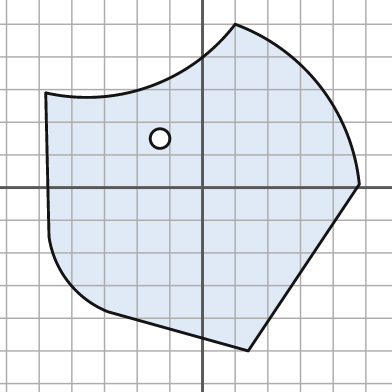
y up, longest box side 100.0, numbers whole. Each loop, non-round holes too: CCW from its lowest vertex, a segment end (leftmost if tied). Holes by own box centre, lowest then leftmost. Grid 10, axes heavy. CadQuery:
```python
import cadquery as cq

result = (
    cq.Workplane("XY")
    .moveTo(14.0, -50.0)
    .lineTo(48.0, 1.0)
    .threePointArc((36.0, 31.0), (10.0, 50.0))
    .threePointArc((-16.0, 31.0), (-48.0, 29.0))
    .lineTo(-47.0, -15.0)
    .threePointArc((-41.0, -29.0), (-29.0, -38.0))
    .close()
    .moveTo(-13.0, 15.0)
    .circle(3.0)
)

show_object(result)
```